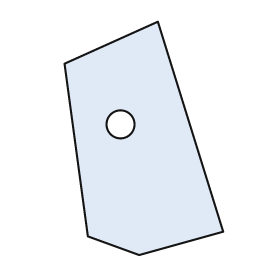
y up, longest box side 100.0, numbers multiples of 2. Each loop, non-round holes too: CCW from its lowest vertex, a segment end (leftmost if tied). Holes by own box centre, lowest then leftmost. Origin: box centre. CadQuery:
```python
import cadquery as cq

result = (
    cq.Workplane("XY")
    .moveTo(-2.0, -50.0)
    .lineTo(34.0, -40.0)
    .lineTo(6.0, 50.0)
    .lineTo(-34.0, 32.0)
    .lineTo(-24.0, -42.0)
    .close()
    .moveTo(-10.0, 6.0)
    .circle(6.0)
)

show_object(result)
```